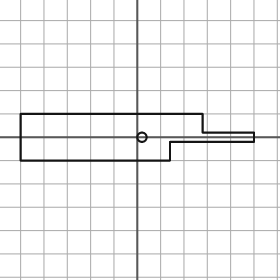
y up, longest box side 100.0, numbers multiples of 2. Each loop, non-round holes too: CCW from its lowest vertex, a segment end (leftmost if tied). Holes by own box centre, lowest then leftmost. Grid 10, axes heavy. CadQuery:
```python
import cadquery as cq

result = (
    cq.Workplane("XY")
    .moveTo(-50.0, -10.0)
    .lineTo(14.0, -10.0)
    .lineTo(14.0, -2.0)
    .lineTo(50.0, -2.0)
    .lineTo(50.0, 2.0)
    .lineTo(28.0, 2.0)
    .lineTo(28.0, 10.0)
    .lineTo(-50.0, 10.0)
    .close()
    .moveTo(2.0, 0.0)
    .circle(2.0)
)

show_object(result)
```